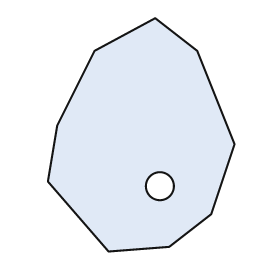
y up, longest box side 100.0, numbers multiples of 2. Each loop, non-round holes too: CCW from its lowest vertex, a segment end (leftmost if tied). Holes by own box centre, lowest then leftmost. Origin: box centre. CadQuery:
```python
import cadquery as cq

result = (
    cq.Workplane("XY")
    .moveTo(-14.0, -50.0)
    .lineTo(12.0, -48.0)
    .lineTo(30.0, -34.0)
    .lineTo(40.0, -4.0)
    .lineTo(24.0, 36.0)
    .lineTo(6.0, 50.0)
    .lineTo(-20.0, 36.0)
    .lineTo(-36.0, 4.0)
    .lineTo(-40.0, -20.0)
    .close()
    .moveTo(8.0, -22.0)
    .circle(6.0)
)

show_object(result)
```